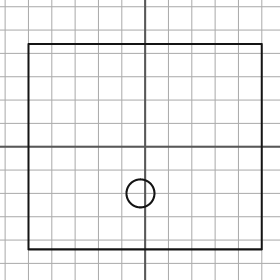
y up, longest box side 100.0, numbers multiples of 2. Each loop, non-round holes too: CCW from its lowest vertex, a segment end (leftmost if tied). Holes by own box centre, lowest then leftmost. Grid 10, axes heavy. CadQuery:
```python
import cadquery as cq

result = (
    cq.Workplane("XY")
    .moveTo(-50.0, -44.0)
    .lineTo(50.0, -44.0)
    .lineTo(50.0, 44.0)
    .lineTo(-50.0, 44.0)
    .close()
    .moveTo(-2.0, -20.0)
    .circle(6.0)
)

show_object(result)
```